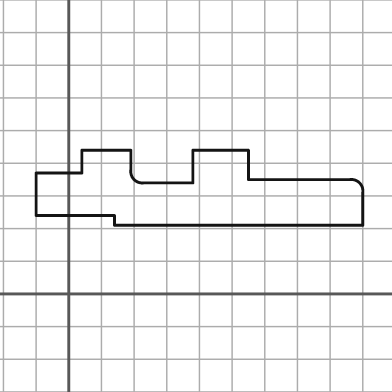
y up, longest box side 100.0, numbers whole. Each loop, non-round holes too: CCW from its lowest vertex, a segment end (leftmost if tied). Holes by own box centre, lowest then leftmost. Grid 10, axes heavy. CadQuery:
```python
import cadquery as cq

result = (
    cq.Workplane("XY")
    .moveTo(14.0, 21.0)
    .lineTo(90.0, 21.0)
    .lineTo(90.0, 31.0)
    .threePointArc((89.0, 34.0), (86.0, 35.0))
    .lineTo(55.0, 35.0)
    .lineTo(55.0, 44.0)
    .lineTo(38.0, 44.0)
    .lineTo(38.0, 34.0)
    .lineTo(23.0, 34.0)
    .threePointArc((20.0, 35.0), (19.0, 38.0))
    .lineTo(19.0, 44.0)
    .lineTo(4.0, 44.0)
    .lineTo(4.0, 37.0)
    .lineTo(-10.0, 37.0)
    .lineTo(-10.0, 24.0)
    .lineTo(14.0, 24.0)
    .close()
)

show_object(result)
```